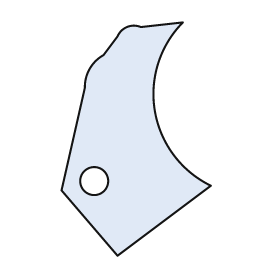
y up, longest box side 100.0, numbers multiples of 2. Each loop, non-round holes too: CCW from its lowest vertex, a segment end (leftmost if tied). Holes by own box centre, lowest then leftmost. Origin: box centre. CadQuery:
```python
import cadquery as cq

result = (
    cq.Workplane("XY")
    .moveTo(-8.0, -50.0)
    .lineTo(32.0, -20.0)
    .threePointArc((8.0, 12.0), (20.0, 50.0))
    .lineTo(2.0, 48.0)
    .threePointArc((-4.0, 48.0), (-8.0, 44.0))
    .lineTo(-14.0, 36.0)
    .threePointArc((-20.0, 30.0), (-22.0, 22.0))
    .lineTo(-32.0, -22.0)
    .close()
    .moveTo(-18.0, -18.0)
    .circle(6.0)
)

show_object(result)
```